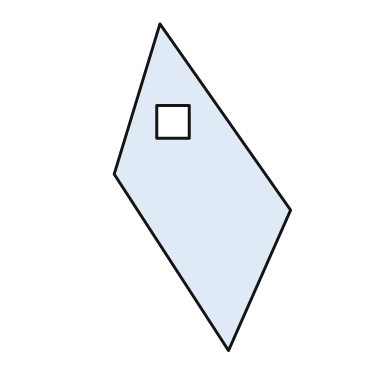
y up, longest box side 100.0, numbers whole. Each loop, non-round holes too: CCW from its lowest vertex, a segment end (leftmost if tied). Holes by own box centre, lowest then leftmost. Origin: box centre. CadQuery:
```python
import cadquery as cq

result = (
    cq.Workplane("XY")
    .moveTo(8.0, -50.0)
    .lineTo(27.0, -7.0)
    .lineTo(-13.0, 50.0)
    .lineTo(-27.0, 4.0)
    .close()
    .moveTo(-14.0, 15.0)
    .lineTo(-4.0, 15.0)
    .lineTo(-4.0, 25.0)
    .lineTo(-14.0, 25.0)
    .close()
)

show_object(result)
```